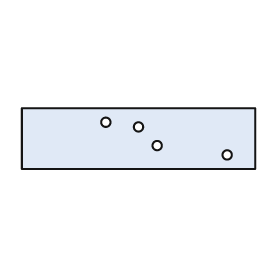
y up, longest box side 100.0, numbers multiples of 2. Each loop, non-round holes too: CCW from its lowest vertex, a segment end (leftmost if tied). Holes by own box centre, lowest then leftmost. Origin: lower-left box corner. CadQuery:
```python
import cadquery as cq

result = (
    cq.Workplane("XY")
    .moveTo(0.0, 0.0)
    .lineTo(100.0, 0.0)
    .lineTo(100.0, 26.0)
    .lineTo(0.0, 26.0)
    .close()
    .moveTo(88.0, 6.0)
    .circle(2.0)
    .moveTo(58.0, 10.0)
    .circle(2.0)
    .moveTo(50.0, 18.0)
    .circle(2.0)
    .moveTo(36.0, 20.0)
    .circle(2.0)
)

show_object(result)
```